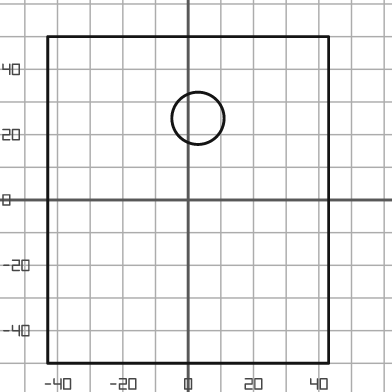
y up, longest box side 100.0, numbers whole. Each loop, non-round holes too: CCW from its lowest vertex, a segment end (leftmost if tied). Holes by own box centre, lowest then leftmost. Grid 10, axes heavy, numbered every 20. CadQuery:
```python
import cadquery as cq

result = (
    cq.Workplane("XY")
    .moveTo(-43.0, -50.0)
    .lineTo(43.0, -50.0)
    .lineTo(43.0, 50.0)
    .lineTo(-43.0, 50.0)
    .close()
    .moveTo(3.0, 25.0)
    .circle(8.0)
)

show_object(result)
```